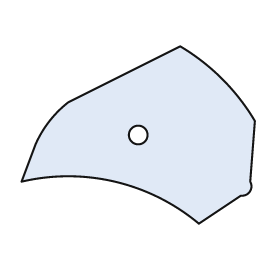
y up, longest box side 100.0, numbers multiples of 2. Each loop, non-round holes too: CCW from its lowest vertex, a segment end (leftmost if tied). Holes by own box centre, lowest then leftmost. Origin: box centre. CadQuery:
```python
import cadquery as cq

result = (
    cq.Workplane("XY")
    .moveTo(26.0, -38.0)
    .lineTo(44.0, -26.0)
    .threePointArc((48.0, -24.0), (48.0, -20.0))
    .lineTo(50.0, 6.0)
    .threePointArc((36.0, 24.0), (18.0, 38.0))
    .lineTo(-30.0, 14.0)
    .threePointArc((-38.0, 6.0), (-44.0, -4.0))
    .lineTo(-50.0, -20.0)
    .threePointArc((-10.0, -20.0), (26.0, -38.0))
    .close()
    .moveTo(0.0, 0.0)
    .circle(4.0)
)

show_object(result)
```